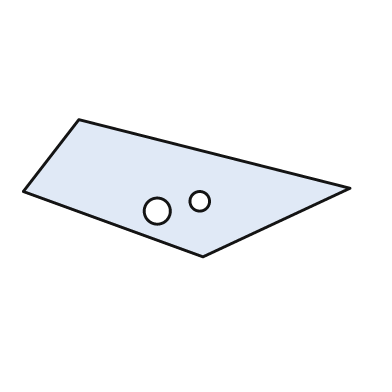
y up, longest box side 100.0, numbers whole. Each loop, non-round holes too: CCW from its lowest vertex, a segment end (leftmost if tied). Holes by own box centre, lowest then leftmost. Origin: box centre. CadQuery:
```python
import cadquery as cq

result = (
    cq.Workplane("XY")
    .moveTo(5.0, -21.0)
    .lineTo(50.0, 0.0)
    .lineTo(-33.0, 21.0)
    .lineTo(-50.0, -1.0)
    .close()
    .moveTo(-9.0, -7.0)
    .circle(4.0)
    .moveTo(4.0, -4.0)
    .circle(3.0)
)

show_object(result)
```